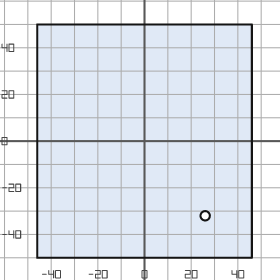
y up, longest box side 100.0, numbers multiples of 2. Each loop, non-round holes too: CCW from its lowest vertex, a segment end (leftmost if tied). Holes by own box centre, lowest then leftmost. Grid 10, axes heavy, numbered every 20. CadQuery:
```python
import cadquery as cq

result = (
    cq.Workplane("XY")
    .moveTo(-46.0, -50.0)
    .lineTo(46.0, -50.0)
    .lineTo(46.0, 50.0)
    .lineTo(-46.0, 50.0)
    .close()
    .moveTo(26.0, -32.0)
    .circle(2.0)
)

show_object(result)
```